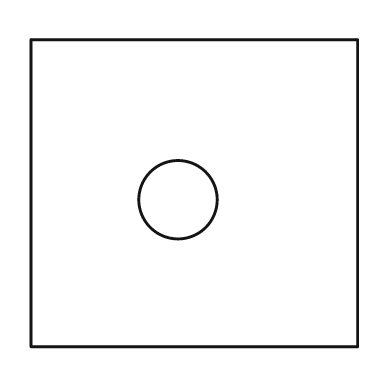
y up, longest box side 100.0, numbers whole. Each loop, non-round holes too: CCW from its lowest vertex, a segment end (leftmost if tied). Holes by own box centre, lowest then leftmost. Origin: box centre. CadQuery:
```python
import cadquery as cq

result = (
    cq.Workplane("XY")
    .moveTo(-50.0, -47.0)
    .lineTo(50.0, -47.0)
    .lineTo(50.0, 47.0)
    .lineTo(-50.0, 47.0)
    .close()
    .moveTo(-5.0, -2.0)
    .circle(12.0)
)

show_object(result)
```